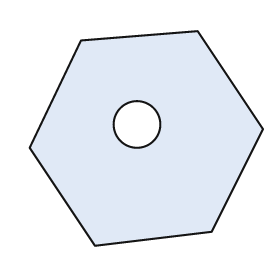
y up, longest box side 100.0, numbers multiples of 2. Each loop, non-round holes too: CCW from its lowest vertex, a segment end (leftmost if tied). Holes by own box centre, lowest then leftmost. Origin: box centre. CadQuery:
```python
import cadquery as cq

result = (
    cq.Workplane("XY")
    .moveTo(-22.0, -46.0)
    .lineTo(28.0, -40.0)
    .lineTo(50.0, 4.0)
    .lineTo(22.0, 46.0)
    .lineTo(-28.0, 42.0)
    .lineTo(-50.0, -4.0)
    .close()
    .moveTo(-4.0, 6.0)
    .circle(10.0)
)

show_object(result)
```